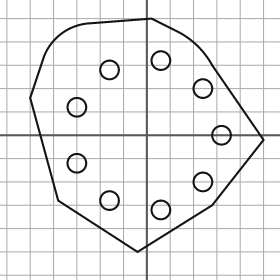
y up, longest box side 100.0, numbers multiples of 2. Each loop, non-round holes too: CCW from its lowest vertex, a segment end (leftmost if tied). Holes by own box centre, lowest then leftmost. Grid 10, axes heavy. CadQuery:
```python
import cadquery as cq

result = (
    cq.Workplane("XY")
    .moveTo(-4.0, -50.0)
    .lineTo(28.0, -30.0)
    .lineTo(50.0, -2.0)
    .lineTo(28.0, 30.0)
    .threePointArc((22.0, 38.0), (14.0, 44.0))
    .lineTo(2.0, 50.0)
    .lineTo(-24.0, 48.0)
    .threePointArc((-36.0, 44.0), (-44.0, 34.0))
    .lineTo(-50.0, 16.0)
    .lineTo(-38.0, -28.0)
    .close()
    .moveTo(6.0, -32.0)
    .circle(4.0)
    .moveTo(-16.0, -28.0)
    .circle(4.0)
    .moveTo(24.0, -20.0)
    .circle(4.0)
    .moveTo(-30.0, -12.0)
    .circle(4.0)
    .moveTo(32.0, 0.0)
    .circle(4.0)
    .moveTo(-30.0, 12.0)
    .circle(4.0)
    .moveTo(24.0, 20.0)
    .circle(4.0)
    .moveTo(-16.0, 28.0)
    .circle(4.0)
    .moveTo(6.0, 32.0)
    .circle(4.0)
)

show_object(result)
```